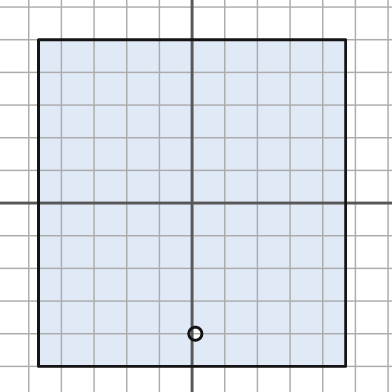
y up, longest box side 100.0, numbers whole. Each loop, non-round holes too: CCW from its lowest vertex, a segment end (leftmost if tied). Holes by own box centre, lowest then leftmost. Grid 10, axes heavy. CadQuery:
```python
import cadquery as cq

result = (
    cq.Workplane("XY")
    .moveTo(-47.0, -50.0)
    .lineTo(47.0, -50.0)
    .lineTo(47.0, 50.0)
    .lineTo(-47.0, 50.0)
    .close()
    .moveTo(1.0, -40.0)
    .circle(2.0)
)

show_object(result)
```